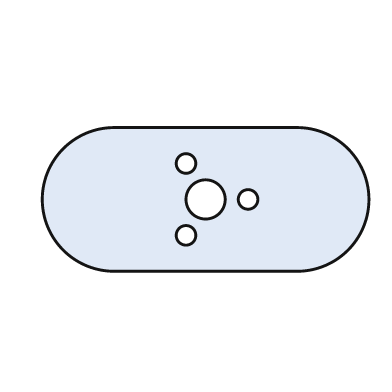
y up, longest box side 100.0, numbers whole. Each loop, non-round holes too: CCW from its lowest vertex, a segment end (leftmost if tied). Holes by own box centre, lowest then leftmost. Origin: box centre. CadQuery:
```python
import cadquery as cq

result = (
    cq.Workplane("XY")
    .moveTo(-28.0, -22.0)
    .lineTo(28.0, -22.0)
    .threePointArc((50.0, 0.0), (28.0, 22.0))
    .lineTo(-28.0, 22.0)
    .threePointArc((-50.0, 0.0), (-28.0, -22.0))
    .close()
    .moveTo(-6.0, -11.0)
    .circle(3.0)
    .moveTo(0.0, 0.0)
    .circle(6.0)
    .moveTo(13.0, 0.0)
    .circle(3.0)
    .moveTo(-6.0, 11.0)
    .circle(3.0)
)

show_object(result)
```